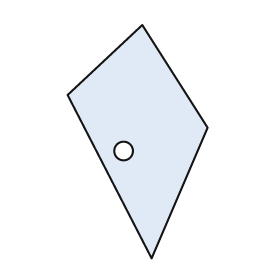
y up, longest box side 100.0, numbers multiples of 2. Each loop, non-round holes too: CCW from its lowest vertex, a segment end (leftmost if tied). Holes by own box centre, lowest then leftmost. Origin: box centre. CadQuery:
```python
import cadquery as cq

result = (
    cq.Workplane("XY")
    .moveTo(6.0, -50.0)
    .lineTo(30.0, 6.0)
    .lineTo(2.0, 50.0)
    .lineTo(-30.0, 20.0)
    .close()
    .moveTo(-6.0, -4.0)
    .circle(4.0)
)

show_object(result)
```